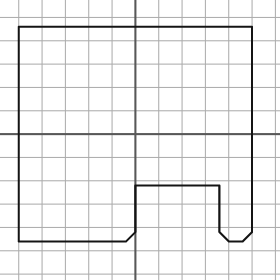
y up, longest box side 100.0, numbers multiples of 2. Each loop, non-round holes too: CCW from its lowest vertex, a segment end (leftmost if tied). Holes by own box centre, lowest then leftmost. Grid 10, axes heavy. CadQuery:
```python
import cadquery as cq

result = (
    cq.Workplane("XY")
    .moveTo(-50.0, -46.0)
    .lineTo(-4.0, -46.0)
    .lineTo(0.0, -42.0)
    .lineTo(0.0, -22.0)
    .lineTo(36.0, -22.0)
    .lineTo(36.0, -42.0)
    .lineTo(40.0, -46.0)
    .lineTo(46.0, -46.0)
    .lineTo(50.0, -42.0)
    .lineTo(50.0, 46.0)
    .lineTo(-50.0, 46.0)
    .close()
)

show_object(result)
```